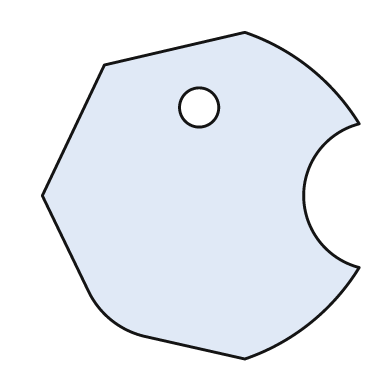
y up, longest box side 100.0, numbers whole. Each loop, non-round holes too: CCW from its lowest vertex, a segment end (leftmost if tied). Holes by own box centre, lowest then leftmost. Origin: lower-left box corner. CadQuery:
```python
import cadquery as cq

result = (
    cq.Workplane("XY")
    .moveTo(62.0, 0.0)
    .threePointArc((82.0, 11.0), (97.0, 28.0))
    .threePointArc((80.0, 50.0), (97.0, 72.0))
    .threePointArc((82.0, 89.0), (62.0, 100.0))
    .lineTo(19.0, 90.0)
    .lineTo(0.0, 50.0)
    .lineTo(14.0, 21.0)
    .threePointArc((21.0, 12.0), (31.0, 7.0))
    .close()
    .moveTo(48.0, 77.0)
    .circle(6.0)
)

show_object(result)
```